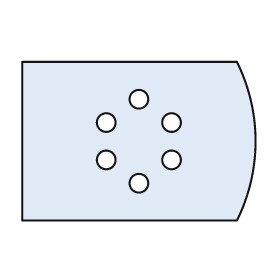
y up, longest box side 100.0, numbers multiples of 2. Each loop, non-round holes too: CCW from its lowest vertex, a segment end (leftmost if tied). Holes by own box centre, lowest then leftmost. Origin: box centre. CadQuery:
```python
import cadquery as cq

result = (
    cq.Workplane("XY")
    .moveTo(-50.0, -34.0)
    .lineTo(42.0, -34.0)
    .threePointArc((50.0, 0.0), (42.0, 34.0))
    .lineTo(-50.0, 34.0)
    .close()
    .moveTo(0.0, -18.0)
    .circle(4.0)
    .moveTo(-14.0, -8.0)
    .circle(4.0)
    .moveTo(14.0, -8.0)
    .circle(4.0)
    .moveTo(-14.0, 8.0)
    .circle(4.0)
    .moveTo(14.0, 8.0)
    .circle(4.0)
    .moveTo(0.0, 18.0)
    .circle(4.0)
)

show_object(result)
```